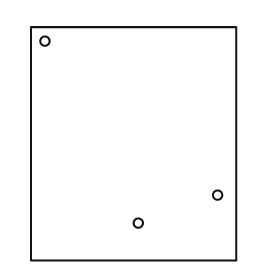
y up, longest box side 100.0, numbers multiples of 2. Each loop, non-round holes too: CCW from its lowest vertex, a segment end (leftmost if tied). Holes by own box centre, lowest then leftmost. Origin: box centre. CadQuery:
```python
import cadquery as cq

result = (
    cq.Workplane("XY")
    .moveTo(-44.0, -50.0)
    .lineTo(44.0, -50.0)
    .lineTo(44.0, 50.0)
    .lineTo(-44.0, 50.0)
    .close()
    .moveTo(2.0, -34.0)
    .circle(2.0)
    .moveTo(36.0, -22.0)
    .circle(2.0)
    .moveTo(-38.0, 44.0)
    .circle(2.0)
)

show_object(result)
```